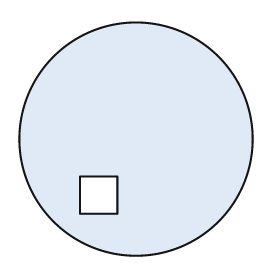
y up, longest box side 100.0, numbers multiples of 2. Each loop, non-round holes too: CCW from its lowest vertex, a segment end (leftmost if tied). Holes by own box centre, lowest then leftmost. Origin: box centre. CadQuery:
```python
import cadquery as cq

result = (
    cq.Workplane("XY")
    .moveTo(0.0, 0.0)
    .circle(50.0)
    .moveTo(-24.0, -32.0)
    .lineTo(-8.0, -32.0)
    .lineTo(-8.0, -16.0)
    .lineTo(-24.0, -16.0)
    .close()
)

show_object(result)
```